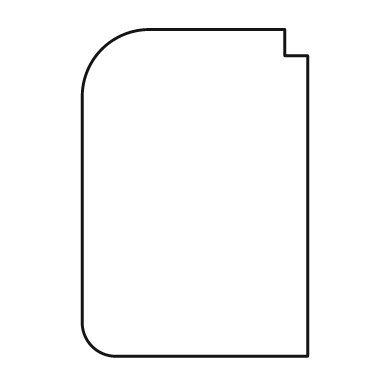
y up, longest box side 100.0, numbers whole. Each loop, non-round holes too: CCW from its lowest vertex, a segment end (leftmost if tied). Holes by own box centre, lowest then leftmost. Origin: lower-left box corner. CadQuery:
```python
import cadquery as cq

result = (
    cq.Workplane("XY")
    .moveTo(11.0, 0.0)
    .lineTo(69.0, 0.0)
    .lineTo(69.0, 92.0)
    .lineTo(62.0, 92.0)
    .lineTo(62.0, 100.0)
    .lineTo(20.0, 100.0)
    .threePointArc((6.0, 94.0), (0.0, 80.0))
    .lineTo(0.0, 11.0)
    .threePointArc((3.0, 3.0), (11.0, 0.0))
    .close()
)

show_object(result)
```